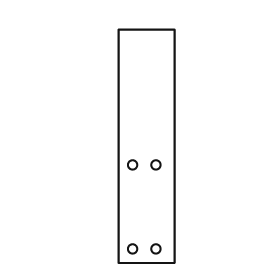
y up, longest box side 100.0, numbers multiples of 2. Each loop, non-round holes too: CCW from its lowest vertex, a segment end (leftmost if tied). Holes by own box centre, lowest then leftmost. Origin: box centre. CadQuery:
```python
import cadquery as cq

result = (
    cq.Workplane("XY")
    .moveTo(-12.0, -50.0)
    .lineTo(12.0, -50.0)
    .lineTo(12.0, 50.0)
    .lineTo(-12.0, 50.0)
    .close()
    .moveTo(-6.0, -44.0)
    .circle(2.0)
    .moveTo(4.0, -44.0)
    .circle(2.0)
    .moveTo(-6.0, -8.0)
    .circle(2.0)
    .moveTo(4.0, -8.0)
    .circle(2.0)
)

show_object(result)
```